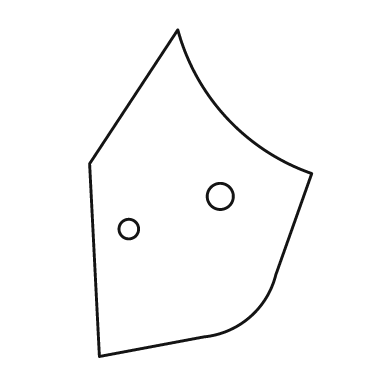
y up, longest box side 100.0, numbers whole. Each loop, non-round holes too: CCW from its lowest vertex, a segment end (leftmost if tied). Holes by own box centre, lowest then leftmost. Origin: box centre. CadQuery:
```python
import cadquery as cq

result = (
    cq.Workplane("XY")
    .moveTo(-31.0, -50.0)
    .lineTo(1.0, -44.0)
    .threePointArc((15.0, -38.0), (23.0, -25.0))
    .lineTo(34.0, 6.0)
    .threePointArc((8.0, 23.0), (-7.0, 50.0))
    .lineTo(-34.0, 9.0)
    .close()
    .moveTo(-22.0, -11.0)
    .circle(3.0)
    .moveTo(6.0, -1.0)
    .circle(4.0)
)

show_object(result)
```